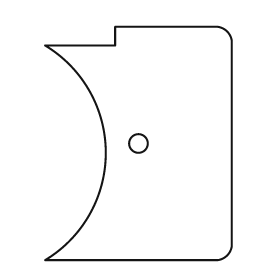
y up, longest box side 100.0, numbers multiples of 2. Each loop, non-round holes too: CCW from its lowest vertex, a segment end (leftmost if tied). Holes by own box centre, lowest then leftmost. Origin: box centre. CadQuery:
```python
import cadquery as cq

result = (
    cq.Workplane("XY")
    .moveTo(-40.0, -50.0)
    .lineTo(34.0, -50.0)
    .threePointArc((38.0, -48.0), (40.0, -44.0))
    .lineTo(40.0, 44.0)
    .threePointArc((38.0, 48.0), (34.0, 50.0))
    .lineTo(-10.0, 50.0)
    .lineTo(-10.0, 42.0)
    .lineTo(-40.0, 42.0)
    .threePointArc((-14.0, -4.0), (-40.0, -50.0))
    .close()
    .moveTo(0.0, 0.0)
    .circle(4.0)
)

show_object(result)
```